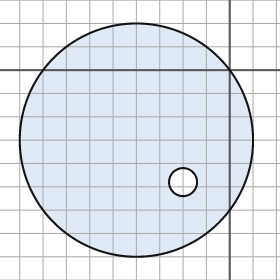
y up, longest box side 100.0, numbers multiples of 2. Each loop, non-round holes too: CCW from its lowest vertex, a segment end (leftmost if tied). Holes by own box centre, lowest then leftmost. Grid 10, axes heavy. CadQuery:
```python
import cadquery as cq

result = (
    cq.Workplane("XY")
    .moveTo(-40.0, -30.0)
    .circle(50.0)
    .moveTo(-20.0, -48.0)
    .circle(6.0)
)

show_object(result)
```